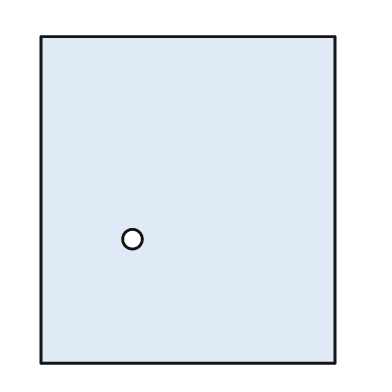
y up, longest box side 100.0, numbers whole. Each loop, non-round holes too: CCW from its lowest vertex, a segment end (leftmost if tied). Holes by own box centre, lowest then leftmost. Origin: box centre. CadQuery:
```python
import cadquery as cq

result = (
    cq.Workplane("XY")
    .moveTo(-45.0, -50.0)
    .lineTo(45.0, -50.0)
    .lineTo(45.0, 50.0)
    .lineTo(-45.0, 50.0)
    .close()
    .moveTo(-17.0, -12.0)
    .circle(3.0)
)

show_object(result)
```